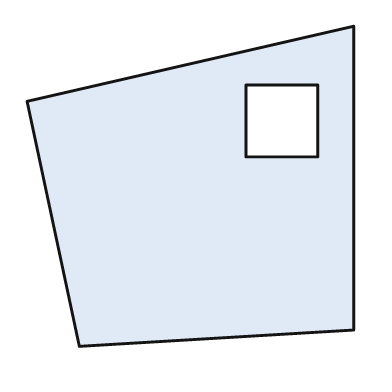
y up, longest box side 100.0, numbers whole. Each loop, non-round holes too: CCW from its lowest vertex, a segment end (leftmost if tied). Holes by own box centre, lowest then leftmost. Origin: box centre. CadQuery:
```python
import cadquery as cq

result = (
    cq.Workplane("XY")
    .moveTo(-34.0, -49.0)
    .lineTo(50.0, -44.0)
    .lineTo(50.0, 49.0)
    .lineTo(-50.0, 26.0)
    .close()
    .moveTo(17.0, 9.0)
    .lineTo(39.0, 9.0)
    .lineTo(39.0, 31.0)
    .lineTo(17.0, 31.0)
    .close()
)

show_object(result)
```